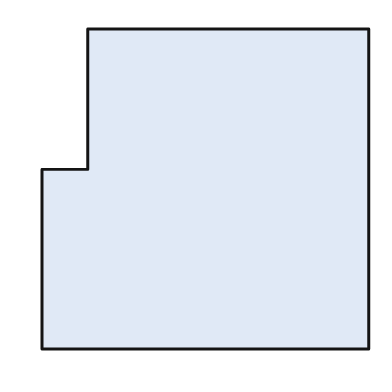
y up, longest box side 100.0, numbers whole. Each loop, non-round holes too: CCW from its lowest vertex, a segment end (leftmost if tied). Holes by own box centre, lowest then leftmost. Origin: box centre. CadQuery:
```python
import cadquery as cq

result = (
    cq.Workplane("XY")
    .moveTo(-50.0, -49.0)
    .lineTo(50.0, -49.0)
    .lineTo(50.0, 49.0)
    .lineTo(-36.0, 49.0)
    .lineTo(-36.0, 6.0)
    .lineTo(-50.0, 6.0)
    .close()
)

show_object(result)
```